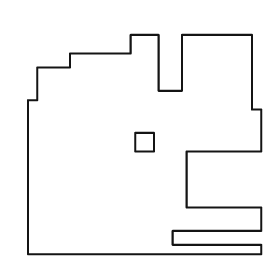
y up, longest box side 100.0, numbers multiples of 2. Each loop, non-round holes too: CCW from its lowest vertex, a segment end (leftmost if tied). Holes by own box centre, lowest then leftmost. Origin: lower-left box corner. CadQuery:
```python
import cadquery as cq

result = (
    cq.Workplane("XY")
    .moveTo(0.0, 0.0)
    .lineTo(100.0, 0.0)
    .lineTo(100.0, 4.0)
    .lineTo(62.0, 4.0)
    .lineTo(62.0, 10.0)
    .lineTo(100.0, 10.0)
    .lineTo(100.0, 20.0)
    .lineTo(68.0, 20.0)
    .lineTo(68.0, 44.0)
    .lineTo(100.0, 44.0)
    .lineTo(100.0, 62.0)
    .lineTo(96.0, 62.0)
    .lineTo(96.0, 94.0)
    .lineTo(66.0, 94.0)
    .lineTo(66.0, 70.0)
    .lineTo(56.0, 70.0)
    .lineTo(56.0, 94.0)
    .lineTo(44.0, 94.0)
    .lineTo(44.0, 86.0)
    .lineTo(18.0, 86.0)
    .lineTo(18.0, 80.0)
    .lineTo(4.0, 80.0)
    .lineTo(4.0, 66.0)
    .lineTo(0.0, 66.0)
    .close()
    .moveTo(46.0, 44.0)
    .lineTo(54.0, 44.0)
    .lineTo(54.0, 52.0)
    .lineTo(46.0, 52.0)
    .close()
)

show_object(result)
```